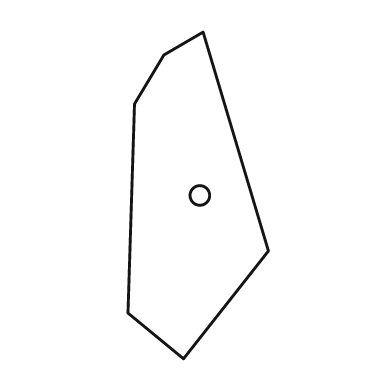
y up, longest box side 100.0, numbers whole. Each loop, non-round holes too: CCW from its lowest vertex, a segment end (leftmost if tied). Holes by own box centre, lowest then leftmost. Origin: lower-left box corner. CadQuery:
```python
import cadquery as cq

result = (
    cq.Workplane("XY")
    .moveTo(17.0, 0.0)
    .lineTo(43.0, 33.0)
    .lineTo(23.0, 100.0)
    .lineTo(11.0, 93.0)
    .lineTo(2.0, 78.0)
    .lineTo(0.0, 14.0)
    .close()
    .moveTo(22.0, 50.0)
    .circle(3.0)
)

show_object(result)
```